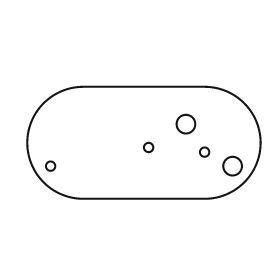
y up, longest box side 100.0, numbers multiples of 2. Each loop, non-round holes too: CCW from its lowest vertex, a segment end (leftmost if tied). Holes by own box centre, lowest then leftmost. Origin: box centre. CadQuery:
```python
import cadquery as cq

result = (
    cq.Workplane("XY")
    .moveTo(-26.0, -24.0)
    .lineTo(26.0, -24.0)
    .threePointArc((50.0, 0.0), (26.0, 24.0))
    .lineTo(-26.0, 24.0)
    .threePointArc((-50.0, 0.0), (-26.0, -24.0))
    .close()
    .moveTo(-40.0, -10.0)
    .circle(2.0)
    .moveTo(38.0, -10.0)
    .circle(4.0)
    .moveTo(26.0, -4.0)
    .circle(2.0)
    .moveTo(2.0, -2.0)
    .circle(2.0)
    .moveTo(18.0, 8.0)
    .circle(4.0)
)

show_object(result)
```